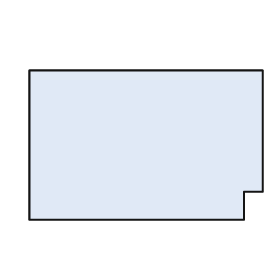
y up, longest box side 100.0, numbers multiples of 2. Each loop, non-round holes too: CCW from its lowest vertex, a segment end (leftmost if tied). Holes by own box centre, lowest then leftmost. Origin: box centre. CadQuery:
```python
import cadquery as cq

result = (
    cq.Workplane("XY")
    .moveTo(-50.0, -32.0)
    .lineTo(42.0, -32.0)
    .lineTo(42.0, -20.0)
    .lineTo(50.0, -20.0)
    .lineTo(50.0, 32.0)
    .lineTo(-50.0, 32.0)
    .close()
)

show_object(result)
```